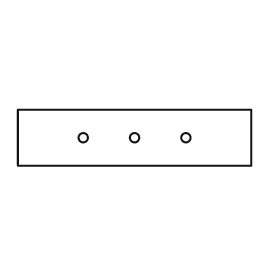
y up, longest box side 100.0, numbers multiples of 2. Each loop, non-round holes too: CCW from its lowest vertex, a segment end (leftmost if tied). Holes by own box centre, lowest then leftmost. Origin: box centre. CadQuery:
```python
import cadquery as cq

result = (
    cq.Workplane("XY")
    .moveTo(-50.0, -12.0)
    .lineTo(50.0, -12.0)
    .lineTo(50.0, 12.0)
    .lineTo(-50.0, 12.0)
    .close()
    .moveTo(-22.0, 0.0)
    .circle(2.0)
    .moveTo(0.0, 0.0)
    .circle(2.0)
    .moveTo(22.0, 0.0)
    .circle(2.0)
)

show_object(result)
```